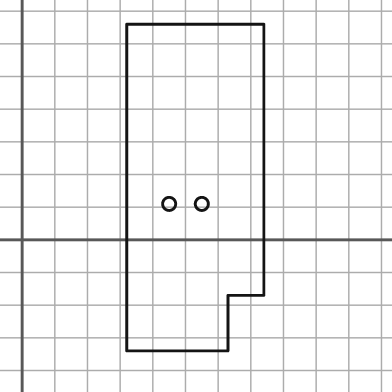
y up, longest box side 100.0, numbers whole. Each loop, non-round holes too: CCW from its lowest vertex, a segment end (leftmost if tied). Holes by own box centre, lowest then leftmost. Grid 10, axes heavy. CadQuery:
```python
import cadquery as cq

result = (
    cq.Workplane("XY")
    .moveTo(32.0, -34.0)
    .lineTo(63.0, -34.0)
    .lineTo(63.0, -17.0)
    .lineTo(74.0, -17.0)
    .lineTo(74.0, 66.0)
    .lineTo(32.0, 66.0)
    .close()
    .moveTo(45.0, 11.0)
    .circle(2.0)
    .moveTo(55.0, 11.0)
    .circle(2.0)
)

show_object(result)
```